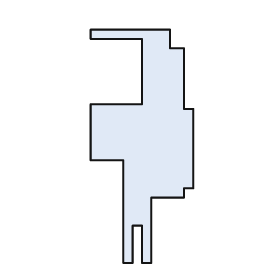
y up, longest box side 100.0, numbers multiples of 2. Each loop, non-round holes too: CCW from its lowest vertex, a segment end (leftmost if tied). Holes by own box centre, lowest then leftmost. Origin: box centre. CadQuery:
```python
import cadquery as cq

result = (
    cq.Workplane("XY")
    .moveTo(-8.0, -50.0)
    .lineTo(-4.0, -50.0)
    .lineTo(-4.0, -34.0)
    .lineTo(0.0, -34.0)
    .lineTo(0.0, -50.0)
    .lineTo(4.0, -50.0)
    .lineTo(4.0, -22.0)
    .lineTo(18.0, -22.0)
    .lineTo(18.0, -18.0)
    .lineTo(22.0, -18.0)
    .lineTo(22.0, 16.0)
    .lineTo(18.0, 16.0)
    .lineTo(18.0, 42.0)
    .lineTo(12.0, 42.0)
    .lineTo(12.0, 50.0)
    .lineTo(-22.0, 50.0)
    .lineTo(-22.0, 46.0)
    .lineTo(0.0, 46.0)
    .lineTo(0.0, 18.0)
    .lineTo(-22.0, 18.0)
    .lineTo(-22.0, -6.0)
    .lineTo(-8.0, -6.0)
    .close()
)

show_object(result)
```